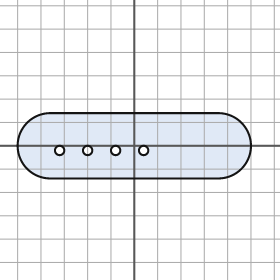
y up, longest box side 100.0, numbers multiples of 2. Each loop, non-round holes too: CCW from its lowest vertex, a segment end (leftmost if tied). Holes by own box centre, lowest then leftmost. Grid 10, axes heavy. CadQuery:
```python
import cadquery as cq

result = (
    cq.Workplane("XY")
    .moveTo(-36.0, -14.0)
    .lineTo(36.0, -14.0)
    .threePointArc((50.0, 0.0), (36.0, 14.0))
    .lineTo(-36.0, 14.0)
    .threePointArc((-50.0, 0.0), (-36.0, -14.0))
    .close()
    .moveTo(-32.0, -2.0)
    .circle(2.0)
    .moveTo(-20.0, -2.0)
    .circle(2.0)
    .moveTo(-8.0, -2.0)
    .circle(2.0)
    .moveTo(4.0, -2.0)
    .circle(2.0)
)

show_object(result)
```